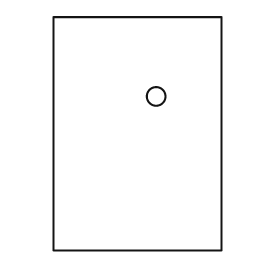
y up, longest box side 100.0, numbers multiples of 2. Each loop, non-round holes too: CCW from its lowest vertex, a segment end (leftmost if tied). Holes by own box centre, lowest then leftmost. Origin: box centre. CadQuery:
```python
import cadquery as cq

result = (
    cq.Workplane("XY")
    .moveTo(-36.0, -50.0)
    .lineTo(36.0, -50.0)
    .lineTo(36.0, 50.0)
    .lineTo(-36.0, 50.0)
    .close()
    .moveTo(8.0, 16.0)
    .circle(4.0)
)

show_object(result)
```